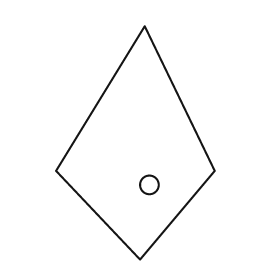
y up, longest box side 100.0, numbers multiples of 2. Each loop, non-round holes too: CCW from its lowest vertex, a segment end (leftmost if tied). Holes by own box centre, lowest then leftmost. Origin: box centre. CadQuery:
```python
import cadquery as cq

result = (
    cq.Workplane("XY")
    .moveTo(2.0, -50.0)
    .lineTo(34.0, -12.0)
    .lineTo(4.0, 50.0)
    .lineTo(-34.0, -12.0)
    .close()
    .moveTo(6.0, -18.0)
    .circle(4.0)
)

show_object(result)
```